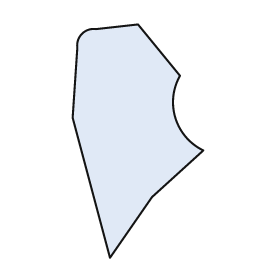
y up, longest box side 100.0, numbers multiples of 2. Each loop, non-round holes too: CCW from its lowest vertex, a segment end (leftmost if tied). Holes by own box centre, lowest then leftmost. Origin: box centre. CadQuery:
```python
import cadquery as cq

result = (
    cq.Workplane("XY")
    .moveTo(-12.0, -50.0)
    .lineTo(6.0, -24.0)
    .lineTo(28.0, -4.0)
    .threePointArc((16.0, 10.0), (18.0, 28.0))
    .lineTo(0.0, 50.0)
    .lineTo(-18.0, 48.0)
    .threePointArc((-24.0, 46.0), (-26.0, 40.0))
    .lineTo(-28.0, 10.0)
    .close()
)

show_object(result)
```